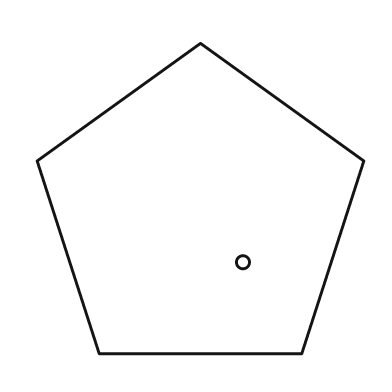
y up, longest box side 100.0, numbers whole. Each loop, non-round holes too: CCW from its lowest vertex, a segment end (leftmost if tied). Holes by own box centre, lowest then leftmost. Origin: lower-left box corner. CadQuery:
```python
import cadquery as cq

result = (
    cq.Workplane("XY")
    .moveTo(19.0, 0.0)
    .lineTo(81.0, 0.0)
    .lineTo(100.0, 59.0)
    .lineTo(50.0, 95.0)
    .lineTo(0.0, 59.0)
    .close()
    .moveTo(63.0, 28.0)
    .circle(2.0)
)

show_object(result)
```